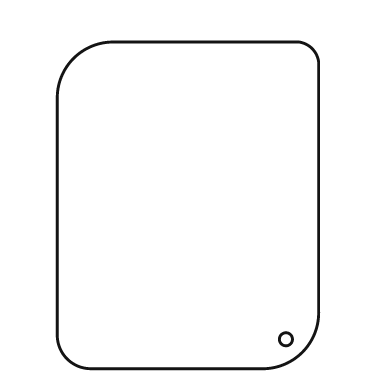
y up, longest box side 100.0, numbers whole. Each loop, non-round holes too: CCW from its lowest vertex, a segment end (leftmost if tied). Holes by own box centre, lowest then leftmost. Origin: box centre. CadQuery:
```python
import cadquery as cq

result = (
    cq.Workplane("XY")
    .moveTo(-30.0, -50.0)
    .lineTo(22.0, -50.0)
    .threePointArc((35.0, -45.0), (40.0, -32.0))
    .lineTo(40.0, 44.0)
    .threePointArc((38.0, 48.0), (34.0, 50.0))
    .lineTo(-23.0, 50.0)
    .threePointArc((-35.0, 45.0), (-40.0, 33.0))
    .lineTo(-40.0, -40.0)
    .threePointArc((-37.0, -47.0), (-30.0, -50.0))
    .close()
    .moveTo(30.0, -41.0)
    .circle(2.0)
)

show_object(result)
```